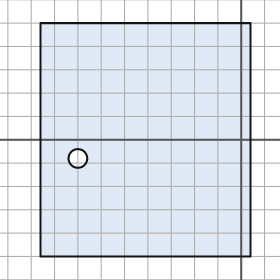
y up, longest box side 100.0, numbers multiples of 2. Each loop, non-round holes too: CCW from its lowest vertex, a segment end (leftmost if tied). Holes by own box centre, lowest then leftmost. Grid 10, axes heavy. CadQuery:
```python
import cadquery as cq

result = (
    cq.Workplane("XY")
    .moveTo(-86.0, -50.0)
    .lineTo(4.0, -50.0)
    .lineTo(4.0, 50.0)
    .lineTo(-86.0, 50.0)
    .close()
    .moveTo(-70.0, -8.0)
    .circle(4.0)
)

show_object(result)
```